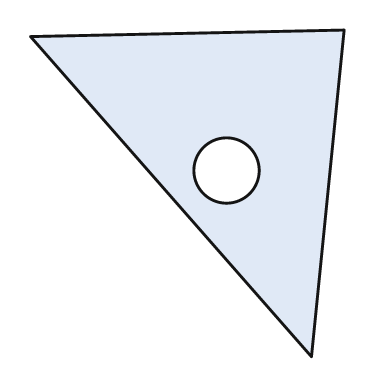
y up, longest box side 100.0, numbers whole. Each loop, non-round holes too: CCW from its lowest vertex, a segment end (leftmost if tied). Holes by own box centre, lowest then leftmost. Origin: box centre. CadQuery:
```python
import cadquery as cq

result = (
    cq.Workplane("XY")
    .moveTo(38.0, -50.0)
    .lineTo(48.0, 50.0)
    .lineTo(-48.0, 48.0)
    .close()
    .moveTo(12.0, 7.0)
    .circle(10.0)
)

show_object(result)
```